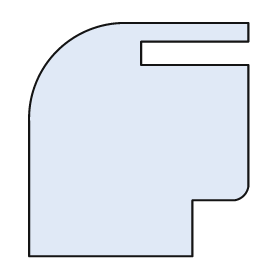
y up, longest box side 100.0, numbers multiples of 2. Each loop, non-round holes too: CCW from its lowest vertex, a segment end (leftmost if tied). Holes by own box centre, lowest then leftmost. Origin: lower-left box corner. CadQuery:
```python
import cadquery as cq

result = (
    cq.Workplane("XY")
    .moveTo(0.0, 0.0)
    .lineTo(70.0, 0.0)
    .lineTo(70.0, 24.0)
    .lineTo(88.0, 24.0)
    .threePointArc((92.0, 26.0), (94.0, 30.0))
    .lineTo(94.0, 82.0)
    .lineTo(48.0, 82.0)
    .lineTo(48.0, 92.0)
    .lineTo(94.0, 92.0)
    .lineTo(94.0, 100.0)
    .lineTo(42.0, 100.0)
    .threePointArc((12.0, 88.0), (0.0, 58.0))
    .close()
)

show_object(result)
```